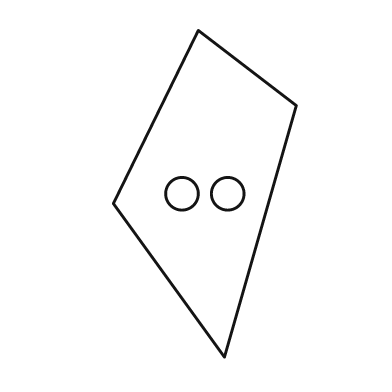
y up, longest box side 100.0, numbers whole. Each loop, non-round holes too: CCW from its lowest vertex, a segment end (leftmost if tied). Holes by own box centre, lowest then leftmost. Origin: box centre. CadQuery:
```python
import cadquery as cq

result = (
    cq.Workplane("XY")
    .moveTo(6.0, -50.0)
    .lineTo(28.0, 27.0)
    .lineTo(-2.0, 50.0)
    .lineTo(-28.0, -3.0)
    .close()
    .moveTo(-7.0, 0.0)
    .circle(5.0)
    .moveTo(7.0, 0.0)
    .circle(5.0)
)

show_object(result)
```